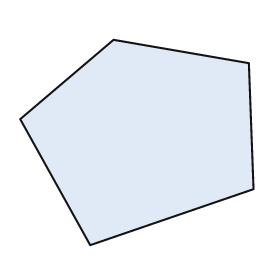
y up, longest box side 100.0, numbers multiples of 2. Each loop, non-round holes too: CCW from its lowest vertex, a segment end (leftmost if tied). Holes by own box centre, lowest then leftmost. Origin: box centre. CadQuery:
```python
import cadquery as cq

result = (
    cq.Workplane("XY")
    .moveTo(-20.0, -44.0)
    .lineTo(50.0, -20.0)
    .lineTo(48.0, 34.0)
    .lineTo(-10.0, 44.0)
    .lineTo(-50.0, 10.0)
    .close()
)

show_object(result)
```